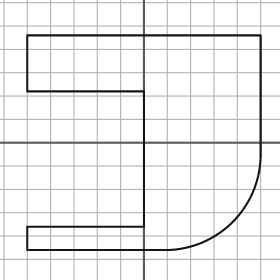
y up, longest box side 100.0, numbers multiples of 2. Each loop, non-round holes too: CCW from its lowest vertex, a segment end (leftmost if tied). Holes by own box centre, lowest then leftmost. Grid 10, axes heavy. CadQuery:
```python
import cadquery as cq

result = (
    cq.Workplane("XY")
    .moveTo(-50.0, -46.0)
    .lineTo(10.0, -46.0)
    .threePointArc((38.0, -34.0), (50.0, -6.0))
    .lineTo(50.0, 46.0)
    .lineTo(-50.0, 46.0)
    .lineTo(-50.0, 22.0)
    .lineTo(0.0, 22.0)
    .lineTo(0.0, -36.0)
    .lineTo(-50.0, -36.0)
    .close()
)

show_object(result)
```